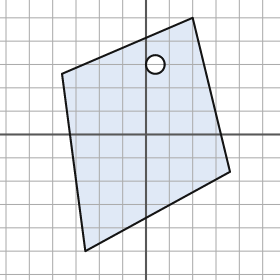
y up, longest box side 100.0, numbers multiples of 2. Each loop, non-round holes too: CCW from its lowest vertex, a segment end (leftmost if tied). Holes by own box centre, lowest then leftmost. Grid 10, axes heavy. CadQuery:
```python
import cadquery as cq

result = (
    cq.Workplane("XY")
    .moveTo(-26.0, -50.0)
    .lineTo(36.0, -16.0)
    .lineTo(20.0, 50.0)
    .lineTo(-36.0, 26.0)
    .close()
    .moveTo(4.0, 30.0)
    .circle(4.0)
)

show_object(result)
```